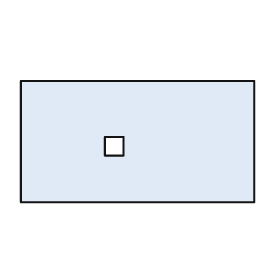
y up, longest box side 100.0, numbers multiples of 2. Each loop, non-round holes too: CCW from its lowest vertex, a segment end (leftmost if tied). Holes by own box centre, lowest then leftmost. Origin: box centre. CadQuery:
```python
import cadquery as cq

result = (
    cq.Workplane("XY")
    .moveTo(-50.0, -26.0)
    .lineTo(50.0, -26.0)
    .lineTo(50.0, 26.0)
    .lineTo(-50.0, 26.0)
    .close()
    .moveTo(-14.0, -6.0)
    .lineTo(-6.0, -6.0)
    .lineTo(-6.0, 2.0)
    .lineTo(-14.0, 2.0)
    .close()
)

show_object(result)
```